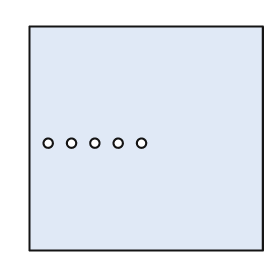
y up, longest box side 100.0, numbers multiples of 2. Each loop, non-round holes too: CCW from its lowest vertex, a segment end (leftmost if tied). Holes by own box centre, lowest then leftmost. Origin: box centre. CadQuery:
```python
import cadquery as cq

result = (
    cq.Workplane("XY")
    .moveTo(-50.0, -48.0)
    .lineTo(50.0, -48.0)
    .lineTo(50.0, 48.0)
    .lineTo(-50.0, 48.0)
    .close()
    .moveTo(-42.0, -2.0)
    .circle(2.0)
    .moveTo(-32.0, -2.0)
    .circle(2.0)
    .moveTo(-22.0, -2.0)
    .circle(2.0)
    .moveTo(-12.0, -2.0)
    .circle(2.0)
    .moveTo(-2.0, -2.0)
    .circle(2.0)
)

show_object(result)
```